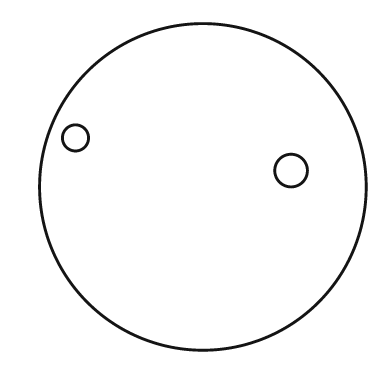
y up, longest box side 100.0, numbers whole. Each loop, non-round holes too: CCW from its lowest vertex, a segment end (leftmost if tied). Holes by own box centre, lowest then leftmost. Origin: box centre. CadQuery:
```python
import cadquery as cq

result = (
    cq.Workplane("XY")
    .moveTo(0.0, 0.0)
    .circle(50.0)
    .moveTo(27.0, 5.0)
    .circle(5.0)
    .moveTo(-39.0, 15.0)
    .circle(4.0)
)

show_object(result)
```